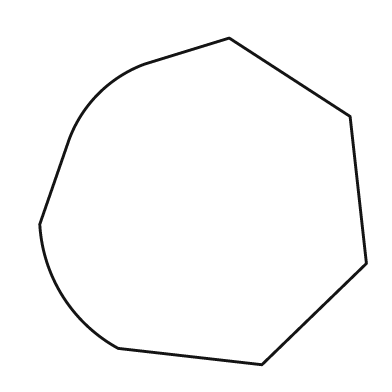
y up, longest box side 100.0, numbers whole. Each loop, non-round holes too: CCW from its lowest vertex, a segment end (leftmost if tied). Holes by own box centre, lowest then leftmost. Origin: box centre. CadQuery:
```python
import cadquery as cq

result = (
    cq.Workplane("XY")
    .moveTo(18.0, -50.0)
    .lineTo(50.0, -19.0)
    .lineTo(45.0, 26.0)
    .lineTo(8.0, 50.0)
    .lineTo(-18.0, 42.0)
    .threePointArc((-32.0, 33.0), (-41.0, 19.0))
    .lineTo(-50.0, -7.0)
    .threePointArc((-43.0, -29.0), (-26.0, -45.0))
    .close()
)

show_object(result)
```